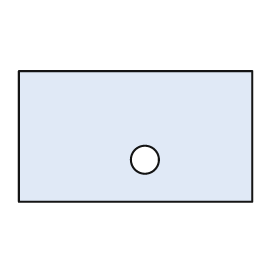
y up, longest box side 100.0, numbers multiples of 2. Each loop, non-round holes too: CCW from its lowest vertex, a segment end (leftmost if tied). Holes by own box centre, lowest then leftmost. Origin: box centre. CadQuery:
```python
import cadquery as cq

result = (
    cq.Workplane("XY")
    .moveTo(-50.0, -28.0)
    .lineTo(50.0, -28.0)
    .lineTo(50.0, 28.0)
    .lineTo(-50.0, 28.0)
    .close()
    .moveTo(4.0, -10.0)
    .circle(6.0)
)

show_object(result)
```